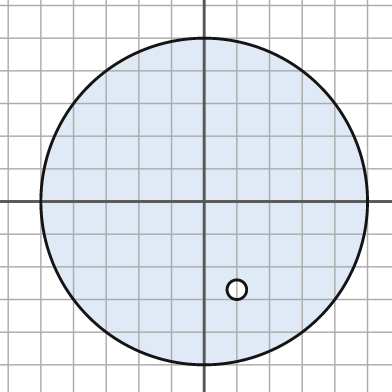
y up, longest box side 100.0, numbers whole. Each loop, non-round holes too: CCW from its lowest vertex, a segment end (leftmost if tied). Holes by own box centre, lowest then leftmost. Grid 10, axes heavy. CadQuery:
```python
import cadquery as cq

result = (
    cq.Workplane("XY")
    .moveTo(0.0, 0.0)
    .circle(50.0)
    .moveTo(10.0, -27.0)
    .circle(3.0)
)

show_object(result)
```